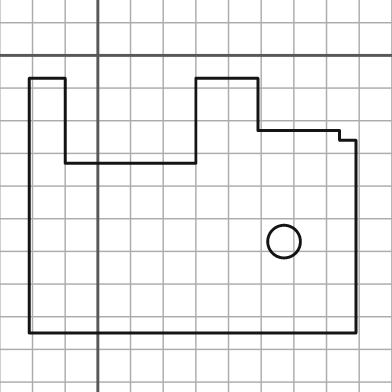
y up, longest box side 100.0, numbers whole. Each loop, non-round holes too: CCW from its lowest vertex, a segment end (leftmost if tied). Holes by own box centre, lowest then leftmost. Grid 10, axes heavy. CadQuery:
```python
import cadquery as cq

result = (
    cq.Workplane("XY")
    .moveTo(-21.0, -85.0)
    .lineTo(79.0, -85.0)
    .lineTo(79.0, -26.0)
    .lineTo(74.0, -26.0)
    .lineTo(74.0, -23.0)
    .lineTo(49.0, -23.0)
    .lineTo(49.0, -7.0)
    .lineTo(30.0, -7.0)
    .lineTo(30.0, -33.0)
    .lineTo(-10.0, -33.0)
    .lineTo(-10.0, -7.0)
    .lineTo(-21.0, -7.0)
    .close()
    .moveTo(57.0, -57.0)
    .circle(5.0)
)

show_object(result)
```